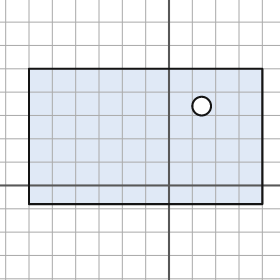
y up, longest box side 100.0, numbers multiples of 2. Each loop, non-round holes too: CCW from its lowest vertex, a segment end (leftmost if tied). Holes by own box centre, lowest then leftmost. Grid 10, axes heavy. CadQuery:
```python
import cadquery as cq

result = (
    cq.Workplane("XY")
    .moveTo(-60.0, -8.0)
    .lineTo(40.0, -8.0)
    .lineTo(40.0, 50.0)
    .lineTo(-60.0, 50.0)
    .close()
    .moveTo(14.0, 34.0)
    .circle(4.0)
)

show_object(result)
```